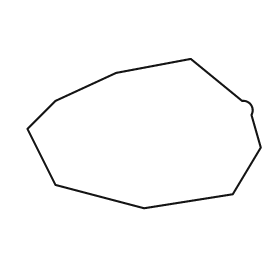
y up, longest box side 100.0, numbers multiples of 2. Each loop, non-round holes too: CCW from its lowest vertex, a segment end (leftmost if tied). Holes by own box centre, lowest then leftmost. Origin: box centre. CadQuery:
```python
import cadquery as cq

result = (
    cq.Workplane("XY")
    .moveTo(0.0, -32.0)
    .lineTo(38.0, -26.0)
    .lineTo(50.0, -6.0)
    .lineTo(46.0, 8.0)
    .threePointArc((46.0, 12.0), (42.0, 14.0))
    .lineTo(20.0, 32.0)
    .lineTo(-12.0, 26.0)
    .lineTo(-38.0, 14.0)
    .lineTo(-50.0, 2.0)
    .lineTo(-38.0, -22.0)
    .close()
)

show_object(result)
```